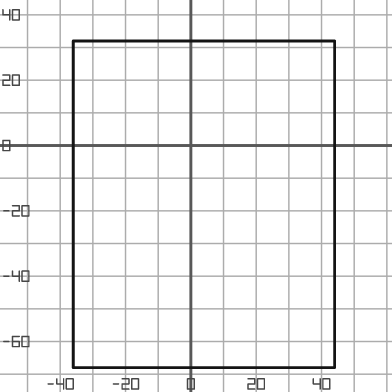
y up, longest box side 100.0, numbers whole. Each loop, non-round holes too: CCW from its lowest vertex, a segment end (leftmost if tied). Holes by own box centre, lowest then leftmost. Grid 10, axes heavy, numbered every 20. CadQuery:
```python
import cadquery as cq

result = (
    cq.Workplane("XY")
    .moveTo(-36.0, -68.0)
    .lineTo(44.0, -68.0)
    .lineTo(44.0, 32.0)
    .lineTo(-36.0, 32.0)
    .close()
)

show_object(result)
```